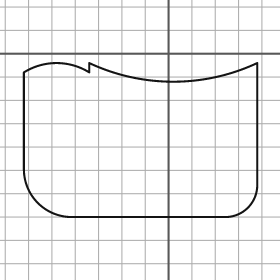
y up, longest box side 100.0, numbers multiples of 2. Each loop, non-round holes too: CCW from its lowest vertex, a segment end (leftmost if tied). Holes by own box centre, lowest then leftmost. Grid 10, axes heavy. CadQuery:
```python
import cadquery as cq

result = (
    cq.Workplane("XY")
    .moveTo(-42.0, -70.0)
    .lineTo(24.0, -70.0)
    .threePointArc((34.0, -66.0), (38.0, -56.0))
    .lineTo(38.0, -4.0)
    .threePointArc((2.0, -12.0), (-34.0, -4.0))
    .lineTo(-34.0, -8.0)
    .threePointArc((-48.0, -4.0), (-62.0, -8.0))
    .lineTo(-62.0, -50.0)
    .threePointArc((-56.0, -64.0), (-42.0, -70.0))
    .close()
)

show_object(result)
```